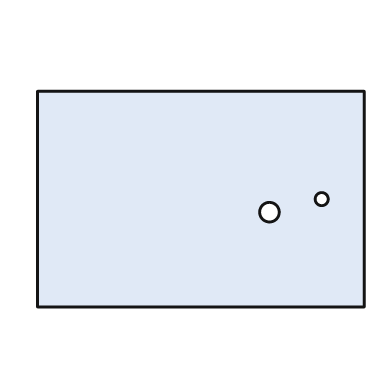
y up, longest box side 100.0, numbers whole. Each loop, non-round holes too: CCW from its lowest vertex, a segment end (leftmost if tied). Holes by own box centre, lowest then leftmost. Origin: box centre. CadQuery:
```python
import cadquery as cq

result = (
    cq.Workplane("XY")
    .moveTo(-50.0, -33.0)
    .lineTo(50.0, -33.0)
    .lineTo(50.0, 33.0)
    .lineTo(-50.0, 33.0)
    .close()
    .moveTo(21.0, -4.0)
    .circle(3.0)
    .moveTo(37.0, 0.0)
    .circle(2.0)
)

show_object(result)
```